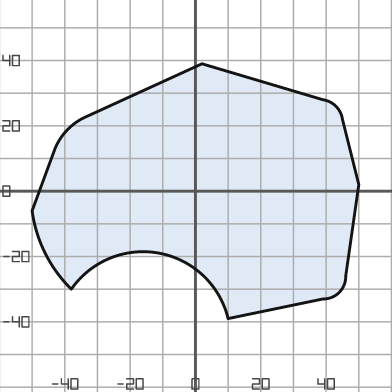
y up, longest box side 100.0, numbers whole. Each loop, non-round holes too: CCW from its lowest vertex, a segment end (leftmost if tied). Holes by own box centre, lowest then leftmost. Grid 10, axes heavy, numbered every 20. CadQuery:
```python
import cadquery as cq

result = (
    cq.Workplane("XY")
    .moveTo(10.0, -39.0)
    .lineTo(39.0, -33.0)
    .threePointArc((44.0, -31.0), (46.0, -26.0))
    .lineTo(50.0, 2.0)
    .lineTo(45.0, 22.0)
    .threePointArc((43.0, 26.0), (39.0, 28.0))
    .lineTo(2.0, 39.0)
    .lineTo(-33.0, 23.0)
    .threePointArc((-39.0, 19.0), (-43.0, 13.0))
    .lineTo(-50.0, -6.0)
    .threePointArc((-46.0, -19.0), (-38.0, -30.0))
    .threePointArc((-11.0, -19.0), (10.0, -39.0))
    .close()
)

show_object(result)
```